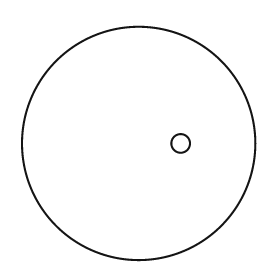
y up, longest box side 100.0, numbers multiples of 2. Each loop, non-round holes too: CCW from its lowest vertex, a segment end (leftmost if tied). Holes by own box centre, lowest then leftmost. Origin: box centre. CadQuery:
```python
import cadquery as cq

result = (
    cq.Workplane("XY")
    .moveTo(0.0, 0.0)
    .circle(50.0)
    .moveTo(18.0, 0.0)
    .circle(4.0)
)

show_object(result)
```